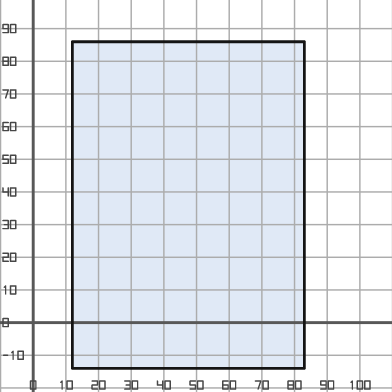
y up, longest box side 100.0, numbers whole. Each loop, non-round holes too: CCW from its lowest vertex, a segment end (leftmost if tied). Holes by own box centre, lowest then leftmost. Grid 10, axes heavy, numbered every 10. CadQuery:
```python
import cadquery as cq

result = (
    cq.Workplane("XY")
    .moveTo(12.0, -14.0)
    .lineTo(83.0, -14.0)
    .lineTo(83.0, 86.0)
    .lineTo(12.0, 86.0)
    .close()
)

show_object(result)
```